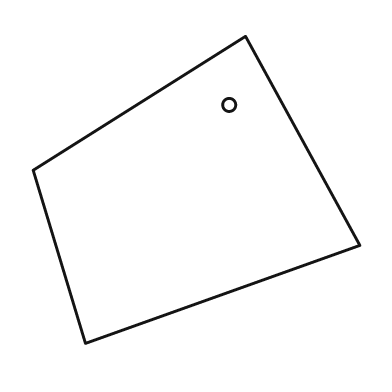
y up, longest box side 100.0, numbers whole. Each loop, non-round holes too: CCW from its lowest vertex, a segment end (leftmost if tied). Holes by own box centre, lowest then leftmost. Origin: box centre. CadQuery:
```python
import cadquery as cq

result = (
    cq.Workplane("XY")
    .moveTo(-34.0, -47.0)
    .lineTo(50.0, -17.0)
    .lineTo(15.0, 47.0)
    .lineTo(-50.0, 6.0)
    .close()
    .moveTo(10.0, 26.0)
    .circle(2.0)
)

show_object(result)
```